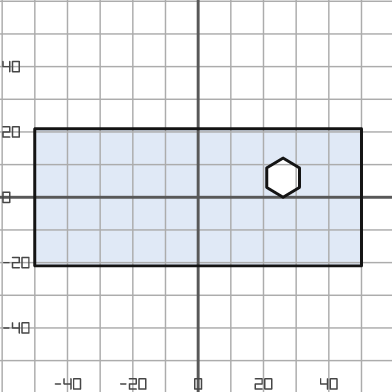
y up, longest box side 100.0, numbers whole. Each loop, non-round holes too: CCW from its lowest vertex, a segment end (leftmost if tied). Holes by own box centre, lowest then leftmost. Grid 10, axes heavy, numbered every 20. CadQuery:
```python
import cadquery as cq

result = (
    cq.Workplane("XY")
    .moveTo(-50.0, -21.0)
    .lineTo(50.0, -21.0)
    .lineTo(50.0, 21.0)
    .lineTo(-50.0, 21.0)
    .close()
    .moveTo(26.0, 0.0)
    .lineTo(31.0, 3.0)
    .lineTo(31.0, 9.0)
    .lineTo(26.0, 12.0)
    .lineTo(21.0, 9.0)
    .lineTo(21.0, 3.0)
    .close()
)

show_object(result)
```